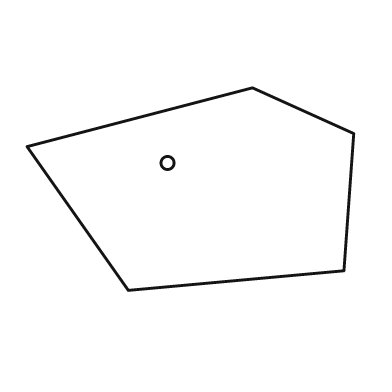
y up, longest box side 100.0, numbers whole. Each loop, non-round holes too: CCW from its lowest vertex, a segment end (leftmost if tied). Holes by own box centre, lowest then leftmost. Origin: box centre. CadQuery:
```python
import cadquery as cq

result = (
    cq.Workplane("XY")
    .moveTo(-19.0, -31.0)
    .lineTo(47.0, -25.0)
    .lineTo(50.0, 17.0)
    .lineTo(19.0, 31.0)
    .lineTo(-50.0, 13.0)
    .close()
    .moveTo(-7.0, 8.0)
    .circle(2.0)
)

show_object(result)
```